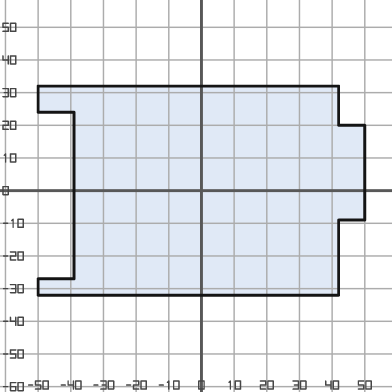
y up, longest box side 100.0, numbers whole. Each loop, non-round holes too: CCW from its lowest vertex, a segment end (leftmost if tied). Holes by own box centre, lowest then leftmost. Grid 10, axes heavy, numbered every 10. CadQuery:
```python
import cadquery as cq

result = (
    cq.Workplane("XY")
    .moveTo(-50.0, -32.0)
    .lineTo(42.0, -32.0)
    .lineTo(42.0, -9.0)
    .lineTo(50.0, -9.0)
    .lineTo(50.0, 20.0)
    .lineTo(42.0, 20.0)
    .lineTo(42.0, 32.0)
    .lineTo(-50.0, 32.0)
    .lineTo(-50.0, 24.0)
    .lineTo(-39.0, 24.0)
    .lineTo(-39.0, -27.0)
    .lineTo(-50.0, -27.0)
    .close()
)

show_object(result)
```